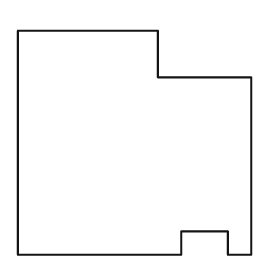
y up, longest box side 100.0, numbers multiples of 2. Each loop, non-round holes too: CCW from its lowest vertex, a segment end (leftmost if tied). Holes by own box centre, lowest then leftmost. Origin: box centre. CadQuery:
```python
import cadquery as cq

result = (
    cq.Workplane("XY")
    .moveTo(-50.0, -48.0)
    .lineTo(20.0, -48.0)
    .lineTo(20.0, -38.0)
    .lineTo(40.0, -38.0)
    .lineTo(40.0, -48.0)
    .lineTo(50.0, -48.0)
    .lineTo(50.0, 28.0)
    .lineTo(10.0, 28.0)
    .lineTo(10.0, 48.0)
    .lineTo(-50.0, 48.0)
    .close()
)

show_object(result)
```